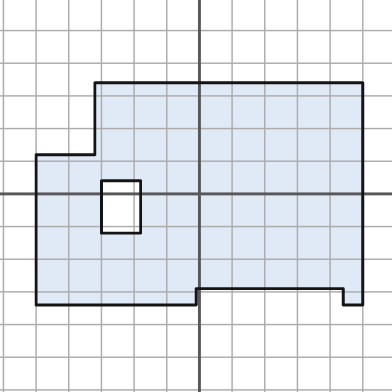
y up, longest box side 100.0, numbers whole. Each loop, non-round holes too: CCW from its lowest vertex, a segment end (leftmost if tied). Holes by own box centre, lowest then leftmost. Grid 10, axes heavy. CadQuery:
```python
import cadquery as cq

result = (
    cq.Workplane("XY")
    .moveTo(-50.0, -34.0)
    .lineTo(-1.0, -34.0)
    .lineTo(-1.0, -29.0)
    .lineTo(44.0, -29.0)
    .lineTo(44.0, -34.0)
    .lineTo(50.0, -34.0)
    .lineTo(50.0, 34.0)
    .lineTo(-32.0, 34.0)
    .lineTo(-32.0, 12.0)
    .lineTo(-50.0, 12.0)
    .close()
    .moveTo(-30.0, -12.0)
    .lineTo(-18.0, -12.0)
    .lineTo(-18.0, 4.0)
    .lineTo(-30.0, 4.0)
    .close()
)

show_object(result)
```